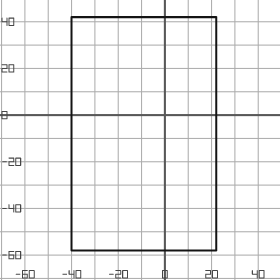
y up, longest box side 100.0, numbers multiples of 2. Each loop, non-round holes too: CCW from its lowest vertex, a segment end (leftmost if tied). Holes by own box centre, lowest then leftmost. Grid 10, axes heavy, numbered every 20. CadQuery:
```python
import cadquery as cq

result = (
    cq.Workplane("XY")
    .moveTo(-40.0, -58.0)
    .lineTo(22.0, -58.0)
    .lineTo(22.0, 42.0)
    .lineTo(-40.0, 42.0)
    .close()
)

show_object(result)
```